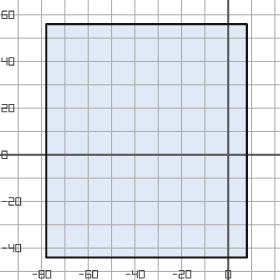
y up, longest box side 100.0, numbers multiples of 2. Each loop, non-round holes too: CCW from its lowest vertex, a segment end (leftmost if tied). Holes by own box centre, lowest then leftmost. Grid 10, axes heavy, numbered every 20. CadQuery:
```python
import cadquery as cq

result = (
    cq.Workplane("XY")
    .moveTo(-78.0, -44.0)
    .lineTo(8.0, -44.0)
    .lineTo(8.0, 56.0)
    .lineTo(-78.0, 56.0)
    .close()
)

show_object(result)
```